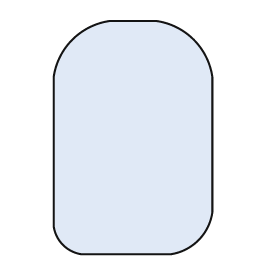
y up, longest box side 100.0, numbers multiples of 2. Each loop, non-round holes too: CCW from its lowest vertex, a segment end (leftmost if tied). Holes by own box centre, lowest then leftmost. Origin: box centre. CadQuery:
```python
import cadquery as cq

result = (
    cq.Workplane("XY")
    .moveTo(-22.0, -50.0)
    .lineTo(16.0, -50.0)
    .threePointArc((28.0, -44.0), (34.0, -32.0))
    .lineTo(34.0, 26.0)
    .threePointArc((26.0, 42.0), (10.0, 50.0))
    .lineTo(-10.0, 50.0)
    .threePointArc((-26.0, 42.0), (-34.0, 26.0))
    .lineTo(-34.0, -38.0)
    .threePointArc((-30.0, -46.0), (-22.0, -50.0))
    .close()
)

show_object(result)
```